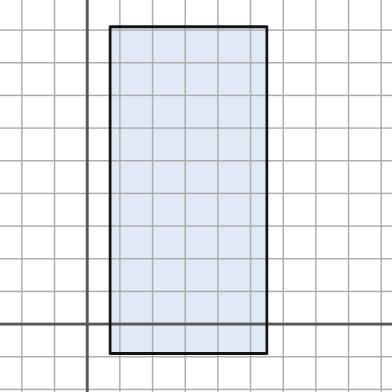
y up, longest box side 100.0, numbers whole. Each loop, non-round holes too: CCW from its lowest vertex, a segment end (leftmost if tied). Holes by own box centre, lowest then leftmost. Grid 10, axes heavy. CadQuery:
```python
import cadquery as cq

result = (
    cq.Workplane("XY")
    .moveTo(7.0, -9.0)
    .lineTo(55.0, -9.0)
    .lineTo(55.0, 91.0)
    .lineTo(7.0, 91.0)
    .close()
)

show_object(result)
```